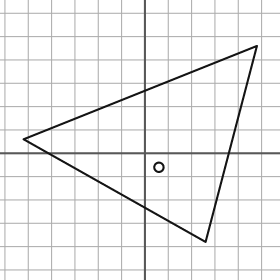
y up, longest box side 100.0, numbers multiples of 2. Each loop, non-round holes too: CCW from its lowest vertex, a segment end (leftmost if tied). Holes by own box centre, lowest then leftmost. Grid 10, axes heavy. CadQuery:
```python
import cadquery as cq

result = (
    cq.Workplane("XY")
    .moveTo(26.0, -38.0)
    .lineTo(48.0, 46.0)
    .lineTo(-52.0, 6.0)
    .close()
    .moveTo(6.0, -6.0)
    .circle(2.0)
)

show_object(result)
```